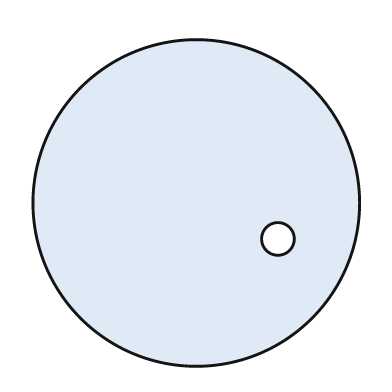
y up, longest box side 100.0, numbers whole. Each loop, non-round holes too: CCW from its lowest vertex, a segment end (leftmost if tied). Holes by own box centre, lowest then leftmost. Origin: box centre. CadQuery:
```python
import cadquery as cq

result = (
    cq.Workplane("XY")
    .moveTo(0.0, 0.0)
    .circle(50.0)
    .moveTo(25.0, -11.0)
    .circle(5.0)
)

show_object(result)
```